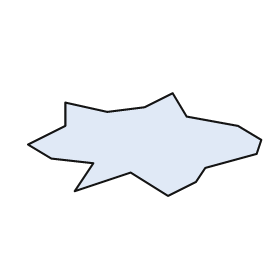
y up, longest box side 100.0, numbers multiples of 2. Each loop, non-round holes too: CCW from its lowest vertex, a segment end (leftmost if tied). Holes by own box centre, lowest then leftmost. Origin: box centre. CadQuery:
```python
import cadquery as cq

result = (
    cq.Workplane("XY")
    .moveTo(10.0, -22.0)
    .lineTo(22.0, -16.0)
    .lineTo(26.0, -10.0)
    .lineTo(48.0, -4.0)
    .lineTo(50.0, 2.0)
    .lineTo(40.0, 8.0)
    .lineTo(18.0, 12.0)
    .lineTo(12.0, 22.0)
    .lineTo(0.0, 16.0)
    .lineTo(-16.0, 14.0)
    .lineTo(-34.0, 18.0)
    .lineTo(-34.0, 8.0)
    .lineTo(-50.0, 0.0)
    .lineTo(-40.0, -6.0)
    .lineTo(-22.0, -8.0)
    .lineTo(-30.0, -20.0)
    .lineTo(-6.0, -12.0)
    .close()
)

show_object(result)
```